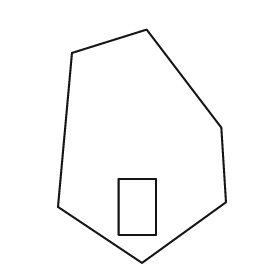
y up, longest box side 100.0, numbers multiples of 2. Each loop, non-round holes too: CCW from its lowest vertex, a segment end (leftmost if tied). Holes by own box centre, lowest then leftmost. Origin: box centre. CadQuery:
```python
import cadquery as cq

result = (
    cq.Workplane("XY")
    .moveTo(0.0, -50.0)
    .lineTo(36.0, -24.0)
    .lineTo(34.0, 8.0)
    .lineTo(2.0, 50.0)
    .lineTo(-30.0, 40.0)
    .lineTo(-36.0, -26.0)
    .close()
    .moveTo(-10.0, -38.0)
    .lineTo(6.0, -38.0)
    .lineTo(6.0, -14.0)
    .lineTo(-10.0, -14.0)
    .close()
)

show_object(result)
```